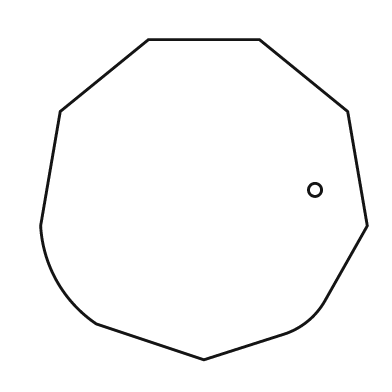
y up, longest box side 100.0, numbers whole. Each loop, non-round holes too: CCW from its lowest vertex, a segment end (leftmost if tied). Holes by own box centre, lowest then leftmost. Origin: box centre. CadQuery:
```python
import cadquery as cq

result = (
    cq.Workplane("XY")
    .moveTo(0.0, -49.0)
    .lineTo(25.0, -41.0)
    .threePointArc((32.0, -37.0), (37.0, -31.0))
    .lineTo(50.0, -8.0)
    .lineTo(44.0, 27.0)
    .lineTo(17.0, 49.0)
    .lineTo(-17.0, 49.0)
    .lineTo(-44.0, 27.0)
    .lineTo(-50.0, -8.0)
    .threePointArc((-45.0, -25.0), (-33.0, -38.0))
    .close()
    .moveTo(34.0, 3.0)
    .circle(2.0)
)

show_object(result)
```